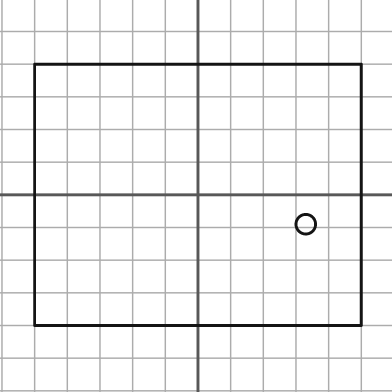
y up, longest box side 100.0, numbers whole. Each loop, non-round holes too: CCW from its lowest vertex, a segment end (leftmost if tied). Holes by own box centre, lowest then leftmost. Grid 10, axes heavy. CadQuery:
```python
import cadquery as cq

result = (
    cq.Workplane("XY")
    .moveTo(-50.0, -40.0)
    .lineTo(50.0, -40.0)
    .lineTo(50.0, 40.0)
    .lineTo(-50.0, 40.0)
    .close()
    .moveTo(33.0, -9.0)
    .circle(3.0)
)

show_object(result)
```